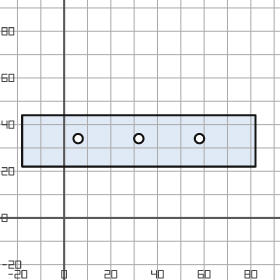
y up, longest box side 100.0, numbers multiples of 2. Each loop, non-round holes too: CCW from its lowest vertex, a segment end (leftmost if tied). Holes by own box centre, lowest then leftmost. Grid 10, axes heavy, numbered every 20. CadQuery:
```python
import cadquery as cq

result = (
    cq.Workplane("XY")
    .moveTo(-18.0, 22.0)
    .lineTo(82.0, 22.0)
    .lineTo(82.0, 44.0)
    .lineTo(-18.0, 44.0)
    .close()
    .moveTo(6.0, 34.0)
    .circle(2.0)
    .moveTo(32.0, 34.0)
    .circle(2.0)
    .moveTo(58.0, 34.0)
    .circle(2.0)
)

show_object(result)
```